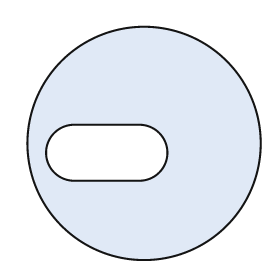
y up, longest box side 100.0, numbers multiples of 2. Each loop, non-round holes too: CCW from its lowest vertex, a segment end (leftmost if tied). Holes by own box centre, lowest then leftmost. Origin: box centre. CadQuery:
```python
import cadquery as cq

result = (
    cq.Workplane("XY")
    .moveTo(0.0, 0.0)
    .circle(50.0)
    .moveTo(-30.0, -16.0)
    .lineTo(-2.0, -16.0)
    .threePointArc((10.0, -4.0), (-2.0, 8.0))
    .lineTo(-30.0, 8.0)
    .threePointArc((-42.0, -4.0), (-30.0, -16.0))
    .close()
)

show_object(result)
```